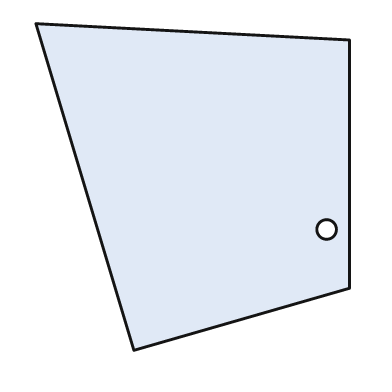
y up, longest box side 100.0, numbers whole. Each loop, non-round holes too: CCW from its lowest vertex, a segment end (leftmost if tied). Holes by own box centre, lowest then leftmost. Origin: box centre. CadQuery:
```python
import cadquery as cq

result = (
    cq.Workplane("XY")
    .moveTo(-18.0, -50.0)
    .lineTo(48.0, -31.0)
    .lineTo(48.0, 45.0)
    .lineTo(-48.0, 50.0)
    .close()
    .moveTo(41.0, -13.0)
    .circle(3.0)
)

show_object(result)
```